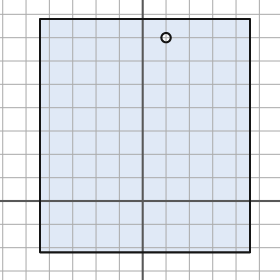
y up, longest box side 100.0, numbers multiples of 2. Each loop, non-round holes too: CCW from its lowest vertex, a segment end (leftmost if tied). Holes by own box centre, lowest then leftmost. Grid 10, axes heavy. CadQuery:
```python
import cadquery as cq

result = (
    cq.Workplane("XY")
    .moveTo(-44.0, -22.0)
    .lineTo(46.0, -22.0)
    .lineTo(46.0, 78.0)
    .lineTo(-44.0, 78.0)
    .close()
    .moveTo(10.0, 70.0)
    .circle(2.0)
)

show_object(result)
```